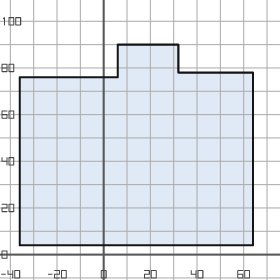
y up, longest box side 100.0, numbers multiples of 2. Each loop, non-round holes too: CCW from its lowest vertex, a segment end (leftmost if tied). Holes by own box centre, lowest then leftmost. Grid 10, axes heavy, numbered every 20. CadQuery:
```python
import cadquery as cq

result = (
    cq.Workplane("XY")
    .moveTo(-36.0, 4.0)
    .lineTo(64.0, 4.0)
    .lineTo(64.0, 78.0)
    .lineTo(32.0, 78.0)
    .lineTo(32.0, 90.0)
    .lineTo(6.0, 90.0)
    .lineTo(6.0, 76.0)
    .lineTo(-36.0, 76.0)
    .close()
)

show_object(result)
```